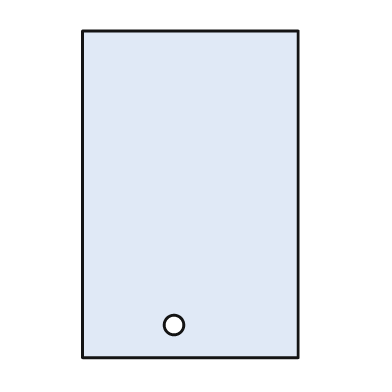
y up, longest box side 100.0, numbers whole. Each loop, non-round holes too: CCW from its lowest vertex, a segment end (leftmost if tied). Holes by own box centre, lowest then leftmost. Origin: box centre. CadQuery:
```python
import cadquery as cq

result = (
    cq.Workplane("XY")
    .moveTo(-33.0, -50.0)
    .lineTo(33.0, -50.0)
    .lineTo(33.0, 50.0)
    .lineTo(-33.0, 50.0)
    .close()
    .moveTo(-5.0, -40.0)
    .circle(3.0)
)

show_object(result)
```